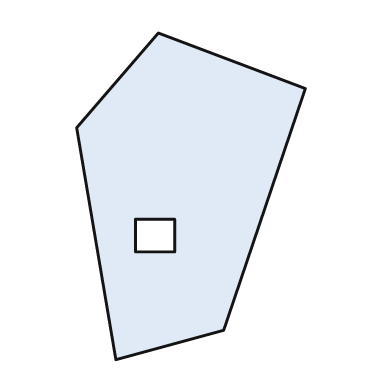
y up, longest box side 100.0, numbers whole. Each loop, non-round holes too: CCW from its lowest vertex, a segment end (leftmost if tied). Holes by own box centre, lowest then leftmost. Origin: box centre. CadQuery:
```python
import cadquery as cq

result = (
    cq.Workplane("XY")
    .moveTo(-23.0, -50.0)
    .lineTo(10.0, -41.0)
    .lineTo(35.0, 33.0)
    .lineTo(-10.0, 50.0)
    .lineTo(-35.0, 21.0)
    .close()
    .moveTo(-17.0, -17.0)
    .lineTo(-5.0, -17.0)
    .lineTo(-5.0, -7.0)
    .lineTo(-17.0, -7.0)
    .close()
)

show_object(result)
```